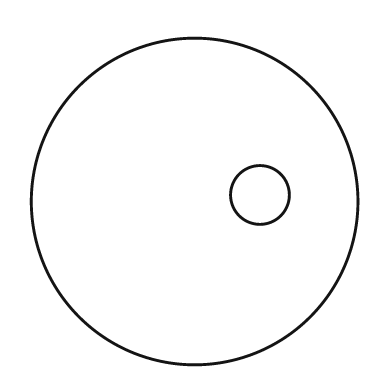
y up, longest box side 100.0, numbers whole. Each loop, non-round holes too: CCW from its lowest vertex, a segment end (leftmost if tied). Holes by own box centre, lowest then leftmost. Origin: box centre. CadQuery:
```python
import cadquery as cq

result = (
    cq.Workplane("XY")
    .moveTo(0.0, 0.0)
    .circle(50.0)
    .moveTo(20.0, 2.0)
    .circle(9.0)
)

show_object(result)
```